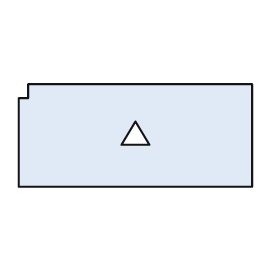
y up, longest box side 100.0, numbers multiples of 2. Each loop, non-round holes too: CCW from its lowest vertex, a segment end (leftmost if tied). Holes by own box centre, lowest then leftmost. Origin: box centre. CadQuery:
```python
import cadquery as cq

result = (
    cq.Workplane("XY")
    .moveTo(-50.0, -22.0)
    .lineTo(50.0, -22.0)
    .lineTo(50.0, 22.0)
    .lineTo(-46.0, 22.0)
    .lineTo(-46.0, 16.0)
    .lineTo(-50.0, 16.0)
    .close()
    .moveTo(-6.0, -4.0)
    .lineTo(6.0, -4.0)
    .lineTo(0.0, 6.0)
    .close()
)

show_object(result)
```